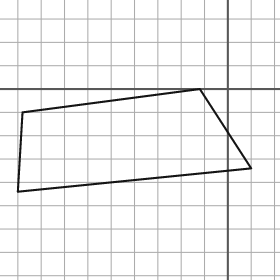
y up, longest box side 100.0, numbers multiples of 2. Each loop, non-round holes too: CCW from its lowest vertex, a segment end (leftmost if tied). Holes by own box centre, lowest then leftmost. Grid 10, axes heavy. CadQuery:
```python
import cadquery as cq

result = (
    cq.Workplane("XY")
    .moveTo(-90.0, -44.0)
    .lineTo(10.0, -34.0)
    .lineTo(-12.0, 0.0)
    .lineTo(-88.0, -10.0)
    .close()
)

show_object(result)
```